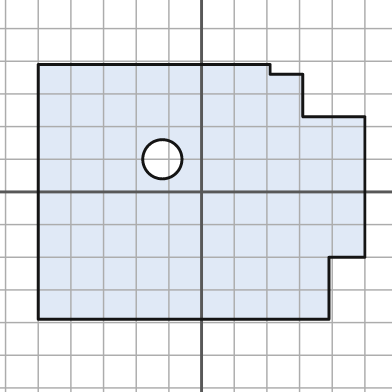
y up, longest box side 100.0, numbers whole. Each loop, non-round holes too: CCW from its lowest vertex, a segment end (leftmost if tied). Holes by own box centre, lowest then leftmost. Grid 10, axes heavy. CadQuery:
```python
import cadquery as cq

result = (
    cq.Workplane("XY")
    .moveTo(-50.0, -39.0)
    .lineTo(39.0, -39.0)
    .lineTo(39.0, -20.0)
    .lineTo(50.0, -20.0)
    .lineTo(50.0, 23.0)
    .lineTo(31.0, 23.0)
    .lineTo(31.0, 36.0)
    .lineTo(21.0, 36.0)
    .lineTo(21.0, 39.0)
    .lineTo(-50.0, 39.0)
    .close()
    .moveTo(-12.0, 10.0)
    .circle(6.0)
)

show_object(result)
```